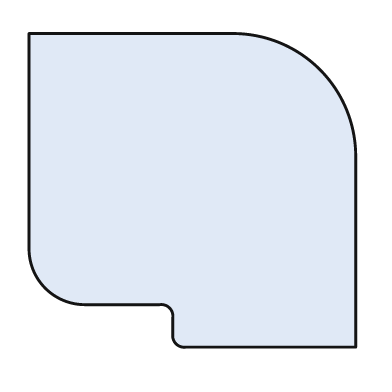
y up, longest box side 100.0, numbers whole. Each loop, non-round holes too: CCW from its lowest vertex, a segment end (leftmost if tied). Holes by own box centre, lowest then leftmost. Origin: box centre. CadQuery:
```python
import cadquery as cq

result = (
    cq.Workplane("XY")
    .moveTo(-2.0, -48.0)
    .lineTo(50.0, -48.0)
    .lineTo(50.0, 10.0)
    .threePointArc((39.0, 37.0), (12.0, 48.0))
    .lineTo(-50.0, 48.0)
    .lineTo(-50.0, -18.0)
    .threePointArc((-45.0, -30.0), (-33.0, -35.0))
    .lineTo(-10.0, -35.0)
    .threePointArc((-7.0, -36.0), (-6.0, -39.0))
    .lineTo(-6.0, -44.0)
    .threePointArc((-5.0, -47.0), (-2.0, -48.0))
    .close()
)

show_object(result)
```